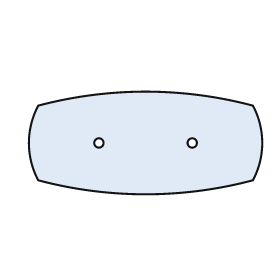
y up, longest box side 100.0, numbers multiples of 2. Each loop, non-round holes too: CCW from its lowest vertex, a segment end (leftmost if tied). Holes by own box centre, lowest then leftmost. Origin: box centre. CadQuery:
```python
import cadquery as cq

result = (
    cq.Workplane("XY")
    .moveTo(-46.0, -16.0)
    .threePointArc((0.0, -22.0), (46.0, -16.0))
    .threePointArc((50.0, 0.0), (46.0, 16.0))
    .threePointArc((0.0, 22.0), (-46.0, 16.0))
    .threePointArc((-50.0, 0.0), (-46.0, -16.0))
    .close()
    .moveTo(-20.0, 0.0)
    .circle(2.0)
    .moveTo(20.0, 0.0)
    .circle(2.0)
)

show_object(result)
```